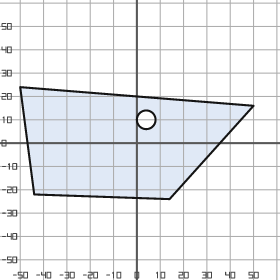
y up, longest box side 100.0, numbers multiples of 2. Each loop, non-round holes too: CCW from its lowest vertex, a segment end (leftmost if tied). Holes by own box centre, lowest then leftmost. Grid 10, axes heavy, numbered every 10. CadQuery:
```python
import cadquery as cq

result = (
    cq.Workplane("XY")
    .moveTo(14.0, -24.0)
    .lineTo(50.0, 16.0)
    .lineTo(-50.0, 24.0)
    .lineTo(-44.0, -22.0)
    .close()
    .moveTo(4.0, 10.0)
    .circle(4.0)
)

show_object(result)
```